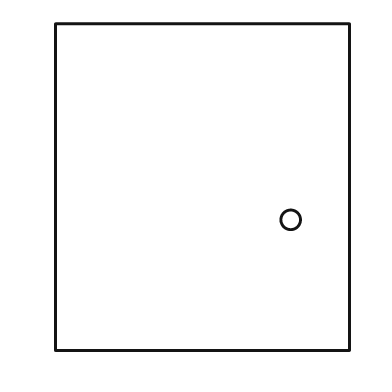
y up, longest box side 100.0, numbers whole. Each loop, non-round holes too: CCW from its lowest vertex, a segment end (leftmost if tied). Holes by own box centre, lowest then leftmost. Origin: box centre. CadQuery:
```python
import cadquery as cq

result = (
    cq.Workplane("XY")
    .moveTo(-45.0, -50.0)
    .lineTo(45.0, -50.0)
    .lineTo(45.0, 50.0)
    .lineTo(-45.0, 50.0)
    .close()
    .moveTo(27.0, -10.0)
    .circle(3.0)
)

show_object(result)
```